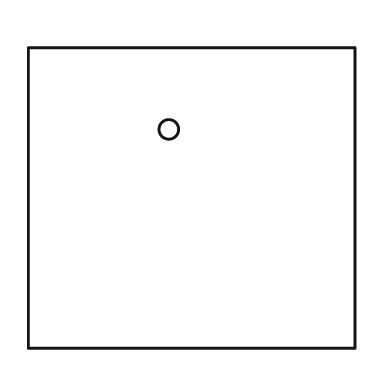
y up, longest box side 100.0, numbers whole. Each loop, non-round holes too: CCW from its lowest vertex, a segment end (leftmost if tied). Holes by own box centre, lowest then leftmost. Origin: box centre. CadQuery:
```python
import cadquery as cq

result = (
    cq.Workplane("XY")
    .moveTo(-50.0, -46.0)
    .lineTo(50.0, -46.0)
    .lineTo(50.0, 46.0)
    .lineTo(-50.0, 46.0)
    .close()
    .moveTo(-7.0, 21.0)
    .circle(3.0)
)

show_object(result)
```